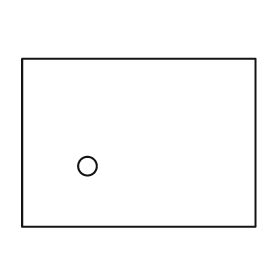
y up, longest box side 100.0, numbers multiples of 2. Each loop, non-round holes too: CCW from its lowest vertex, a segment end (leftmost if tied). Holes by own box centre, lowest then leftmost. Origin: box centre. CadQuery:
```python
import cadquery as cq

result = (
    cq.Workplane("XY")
    .moveTo(-50.0, -36.0)
    .lineTo(50.0, -36.0)
    .lineTo(50.0, 36.0)
    .lineTo(-50.0, 36.0)
    .close()
    .moveTo(-22.0, -10.0)
    .circle(4.0)
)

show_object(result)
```